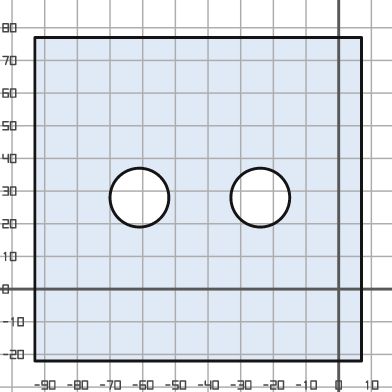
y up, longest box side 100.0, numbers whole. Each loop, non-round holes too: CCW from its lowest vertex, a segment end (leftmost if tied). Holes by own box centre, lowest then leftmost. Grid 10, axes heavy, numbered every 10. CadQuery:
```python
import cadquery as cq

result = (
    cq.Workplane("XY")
    .moveTo(-93.0, -22.0)
    .lineTo(7.0, -22.0)
    .lineTo(7.0, 77.0)
    .lineTo(-93.0, 77.0)
    .close()
    .moveTo(-61.0, 28.0)
    .circle(9.0)
    .moveTo(-24.0, 28.0)
    .circle(9.0)
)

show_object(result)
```